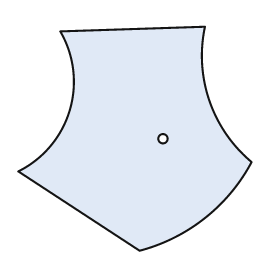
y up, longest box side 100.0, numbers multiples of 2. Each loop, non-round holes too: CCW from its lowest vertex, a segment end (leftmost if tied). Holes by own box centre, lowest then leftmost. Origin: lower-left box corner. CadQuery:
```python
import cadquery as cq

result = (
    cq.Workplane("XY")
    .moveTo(52.0, 0.0)
    .threePointArc((80.0, 14.0), (100.0, 38.0))
    .threePointArc((82.0, 64.0), (80.0, 96.0))
    .lineTo(18.0, 94.0)
    .threePointArc((22.0, 60.0), (0.0, 34.0))
    .close()
    .moveTo(62.0, 48.0)
    .circle(2.0)
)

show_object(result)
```